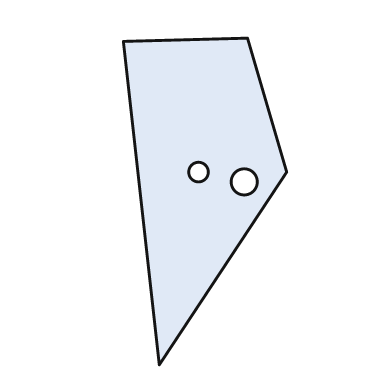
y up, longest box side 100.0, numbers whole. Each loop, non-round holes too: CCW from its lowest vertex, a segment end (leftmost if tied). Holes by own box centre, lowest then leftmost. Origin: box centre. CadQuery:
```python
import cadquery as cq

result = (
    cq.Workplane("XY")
    .moveTo(-14.0, -50.0)
    .lineTo(25.0, 9.0)
    .lineTo(13.0, 50.0)
    .lineTo(-25.0, 49.0)
    .close()
    .moveTo(12.0, 6.0)
    .circle(4.0)
    .moveTo(-2.0, 9.0)
    .circle(3.0)
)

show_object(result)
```